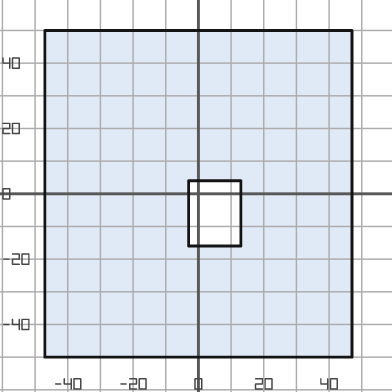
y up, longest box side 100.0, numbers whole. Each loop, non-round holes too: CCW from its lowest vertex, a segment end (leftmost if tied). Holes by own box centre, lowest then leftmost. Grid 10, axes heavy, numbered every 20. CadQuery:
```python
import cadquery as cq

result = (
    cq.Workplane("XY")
    .moveTo(-47.0, -50.0)
    .lineTo(47.0, -50.0)
    .lineTo(47.0, 50.0)
    .lineTo(-47.0, 50.0)
    .close()
    .moveTo(-3.0, -16.0)
    .lineTo(13.0, -16.0)
    .lineTo(13.0, 4.0)
    .lineTo(-3.0, 4.0)
    .close()
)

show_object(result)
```